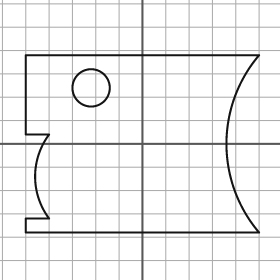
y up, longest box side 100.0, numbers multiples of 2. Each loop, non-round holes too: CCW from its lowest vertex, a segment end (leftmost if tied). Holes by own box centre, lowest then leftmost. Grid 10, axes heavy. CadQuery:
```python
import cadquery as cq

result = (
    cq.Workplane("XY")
    .moveTo(-50.0, -38.0)
    .lineTo(50.0, -38.0)
    .threePointArc((36.0, 0.0), (50.0, 38.0))
    .lineTo(-50.0, 38.0)
    .lineTo(-50.0, 4.0)
    .lineTo(-40.0, 4.0)
    .threePointArc((-46.0, -14.0), (-40.0, -32.0))
    .lineTo(-50.0, -32.0)
    .close()
    .moveTo(-22.0, 24.0)
    .circle(8.0)
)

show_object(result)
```